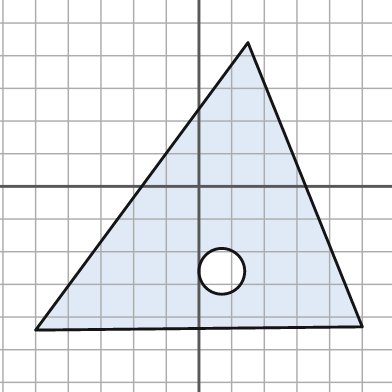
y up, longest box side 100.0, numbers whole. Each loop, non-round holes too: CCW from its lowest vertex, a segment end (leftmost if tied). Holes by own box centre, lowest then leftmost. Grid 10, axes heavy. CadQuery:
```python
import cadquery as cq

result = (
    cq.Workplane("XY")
    .moveTo(-50.0, -44.0)
    .lineTo(50.0, -43.0)
    .lineTo(15.0, 44.0)
    .close()
    .moveTo(7.0, -26.0)
    .circle(7.0)
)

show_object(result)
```